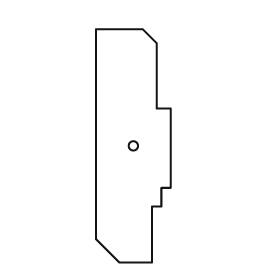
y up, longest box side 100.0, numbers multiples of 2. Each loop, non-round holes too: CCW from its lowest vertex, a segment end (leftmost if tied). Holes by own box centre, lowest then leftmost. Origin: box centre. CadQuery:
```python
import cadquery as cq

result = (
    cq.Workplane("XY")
    .moveTo(-6.0, -50.0)
    .lineTo(8.0, -50.0)
    .lineTo(8.0, -26.0)
    .lineTo(12.0, -26.0)
    .lineTo(12.0, -18.0)
    .lineTo(16.0, -18.0)
    .lineTo(16.0, 16.0)
    .lineTo(10.0, 16.0)
    .lineTo(10.0, 44.0)
    .lineTo(4.0, 50.0)
    .lineTo(-16.0, 50.0)
    .lineTo(-16.0, -40.0)
    .close()
    .moveTo(0.0, 0.0)
    .circle(2.0)
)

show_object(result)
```